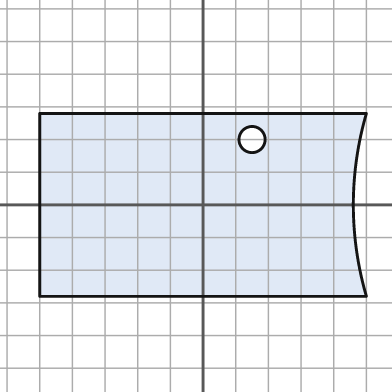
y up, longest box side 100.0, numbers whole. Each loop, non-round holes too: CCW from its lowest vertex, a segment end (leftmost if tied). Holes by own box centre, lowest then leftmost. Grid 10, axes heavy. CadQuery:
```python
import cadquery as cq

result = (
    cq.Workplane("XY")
    .moveTo(-50.0, -28.0)
    .lineTo(50.0, -28.0)
    .threePointArc((46.0, 0.0), (50.0, 28.0))
    .lineTo(-50.0, 28.0)
    .close()
    .moveTo(15.0, 20.0)
    .circle(4.0)
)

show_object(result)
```